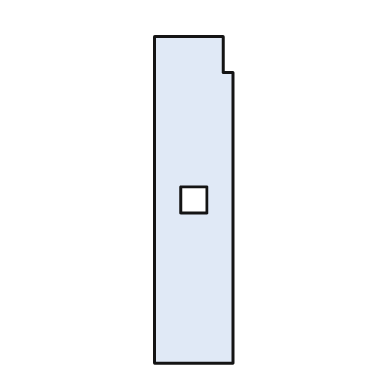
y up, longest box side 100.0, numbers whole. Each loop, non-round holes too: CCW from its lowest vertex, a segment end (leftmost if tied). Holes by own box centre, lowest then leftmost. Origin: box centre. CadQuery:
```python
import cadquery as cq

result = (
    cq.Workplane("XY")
    .moveTo(-12.0, -50.0)
    .lineTo(12.0, -50.0)
    .lineTo(12.0, 39.0)
    .lineTo(9.0, 39.0)
    .lineTo(9.0, 50.0)
    .lineTo(-12.0, 50.0)
    .close()
    .moveTo(-4.0, -4.0)
    .lineTo(4.0, -4.0)
    .lineTo(4.0, 4.0)
    .lineTo(-4.0, 4.0)
    .close()
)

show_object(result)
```